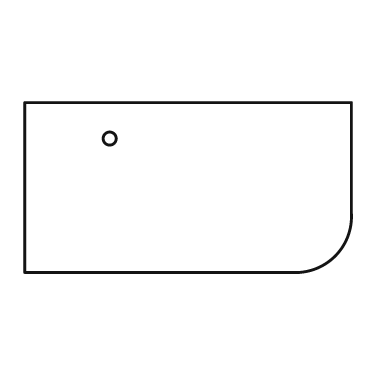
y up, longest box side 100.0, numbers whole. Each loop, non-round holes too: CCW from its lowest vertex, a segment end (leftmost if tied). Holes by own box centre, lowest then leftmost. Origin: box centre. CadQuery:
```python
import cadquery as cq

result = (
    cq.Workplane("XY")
    .moveTo(-50.0, -26.0)
    .lineTo(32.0, -26.0)
    .threePointArc((45.0, -21.0), (50.0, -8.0))
    .lineTo(50.0, 26.0)
    .lineTo(-50.0, 26.0)
    .close()
    .moveTo(-24.0, 15.0)
    .circle(2.0)
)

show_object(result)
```